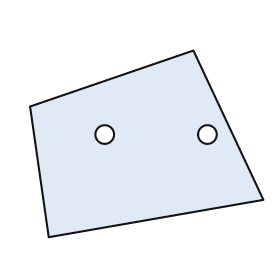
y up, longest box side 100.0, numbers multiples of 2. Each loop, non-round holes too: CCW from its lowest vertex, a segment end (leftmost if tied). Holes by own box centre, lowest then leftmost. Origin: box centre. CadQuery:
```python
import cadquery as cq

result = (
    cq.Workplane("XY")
    .moveTo(-42.0, -40.0)
    .lineTo(50.0, -24.0)
    .lineTo(20.0, 40.0)
    .lineTo(-50.0, 16.0)
    .close()
    .moveTo(-18.0, 4.0)
    .circle(4.0)
    .moveTo(26.0, 4.0)
    .circle(4.0)
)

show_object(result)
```